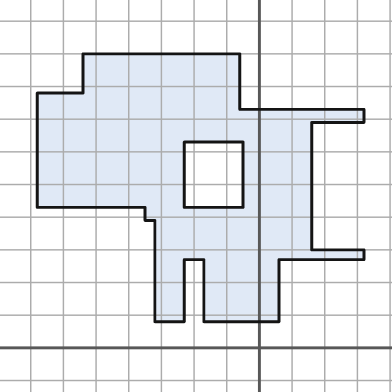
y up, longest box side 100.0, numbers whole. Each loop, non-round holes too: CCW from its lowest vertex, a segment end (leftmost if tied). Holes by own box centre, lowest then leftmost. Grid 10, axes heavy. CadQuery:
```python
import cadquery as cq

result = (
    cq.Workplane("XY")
    .moveTo(-32.0, 8.0)
    .lineTo(-23.0, 8.0)
    .lineTo(-23.0, 27.0)
    .lineTo(-17.0, 27.0)
    .lineTo(-17.0, 8.0)
    .lineTo(6.0, 8.0)
    .lineTo(6.0, 27.0)
    .lineTo(32.0, 27.0)
    .lineTo(32.0, 30.0)
    .lineTo(16.0, 30.0)
    .lineTo(16.0, 69.0)
    .lineTo(32.0, 69.0)
    .lineTo(32.0, 73.0)
    .lineTo(-6.0, 73.0)
    .lineTo(-6.0, 90.0)
    .lineTo(-54.0, 90.0)
    .lineTo(-54.0, 78.0)
    .lineTo(-68.0, 78.0)
    .lineTo(-68.0, 43.0)
    .lineTo(-35.0, 43.0)
    .lineTo(-35.0, 39.0)
    .lineTo(-32.0, 39.0)
    .close()
    .moveTo(-23.0, 43.0)
    .lineTo(-5.0, 43.0)
    .lineTo(-5.0, 63.0)
    .lineTo(-23.0, 63.0)
    .close()
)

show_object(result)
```